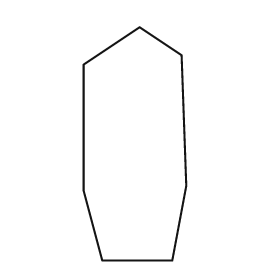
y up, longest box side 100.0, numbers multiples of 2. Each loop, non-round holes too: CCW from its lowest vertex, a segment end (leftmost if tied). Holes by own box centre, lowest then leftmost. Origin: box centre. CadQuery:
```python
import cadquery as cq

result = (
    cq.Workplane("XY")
    .moveTo(-14.0, -50.0)
    .lineTo(16.0, -50.0)
    .lineTo(22.0, -18.0)
    .lineTo(20.0, 38.0)
    .lineTo(2.0, 50.0)
    .lineTo(-22.0, 34.0)
    .lineTo(-22.0, -20.0)
    .close()
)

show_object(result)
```